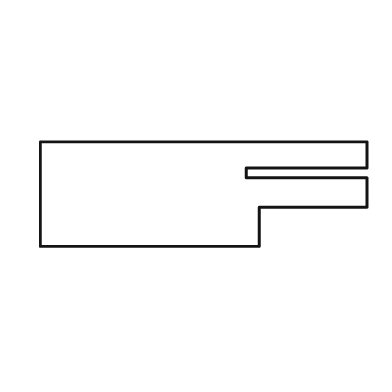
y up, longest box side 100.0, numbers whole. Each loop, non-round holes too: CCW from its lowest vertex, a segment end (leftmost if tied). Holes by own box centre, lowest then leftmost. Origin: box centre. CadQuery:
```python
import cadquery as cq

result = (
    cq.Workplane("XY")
    .moveTo(-50.0, -16.0)
    .lineTo(17.0, -16.0)
    .lineTo(17.0, -4.0)
    .lineTo(50.0, -4.0)
    .lineTo(50.0, 5.0)
    .lineTo(13.0, 5.0)
    .lineTo(13.0, 8.0)
    .lineTo(50.0, 8.0)
    .lineTo(50.0, 16.0)
    .lineTo(-50.0, 16.0)
    .close()
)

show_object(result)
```